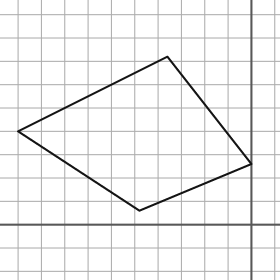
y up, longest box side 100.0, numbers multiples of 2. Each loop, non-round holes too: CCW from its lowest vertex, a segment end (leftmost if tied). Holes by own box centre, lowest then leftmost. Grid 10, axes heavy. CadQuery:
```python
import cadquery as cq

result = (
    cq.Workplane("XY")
    .moveTo(-48.0, 6.0)
    .lineTo(0.0, 26.0)
    .lineTo(-36.0, 72.0)
    .lineTo(-100.0, 40.0)
    .close()
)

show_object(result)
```